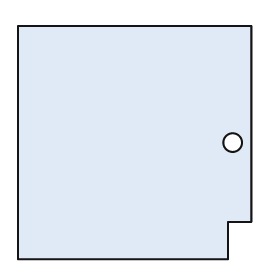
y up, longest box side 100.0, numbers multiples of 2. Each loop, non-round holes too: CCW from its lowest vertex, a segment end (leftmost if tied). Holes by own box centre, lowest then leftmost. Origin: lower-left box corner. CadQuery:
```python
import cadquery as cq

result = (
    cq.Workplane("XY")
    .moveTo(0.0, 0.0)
    .lineTo(90.0, 0.0)
    .lineTo(90.0, 16.0)
    .lineTo(100.0, 16.0)
    .lineTo(100.0, 100.0)
    .lineTo(0.0, 100.0)
    .close()
    .moveTo(92.0, 50.0)
    .circle(4.0)
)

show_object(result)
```